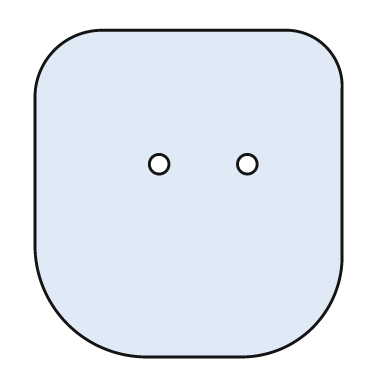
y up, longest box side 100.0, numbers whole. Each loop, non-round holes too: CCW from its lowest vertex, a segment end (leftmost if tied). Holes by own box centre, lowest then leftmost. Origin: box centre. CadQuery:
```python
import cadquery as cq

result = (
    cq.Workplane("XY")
    .moveTo(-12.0, -50.0)
    .lineTo(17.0, -50.0)
    .threePointArc((38.0, -41.0), (47.0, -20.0))
    .lineTo(47.0, 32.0)
    .threePointArc((42.0, 45.0), (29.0, 50.0))
    .lineTo(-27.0, 50.0)
    .threePointArc((-41.0, 44.0), (-47.0, 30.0))
    .lineTo(-47.0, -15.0)
    .threePointArc((-37.0, -40.0), (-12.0, -50.0))
    .close()
    .moveTo(-9.0, 9.0)
    .circle(3.0)
    .moveTo(18.0, 9.0)
    .circle(3.0)
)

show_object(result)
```